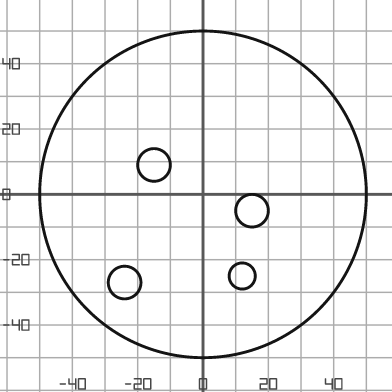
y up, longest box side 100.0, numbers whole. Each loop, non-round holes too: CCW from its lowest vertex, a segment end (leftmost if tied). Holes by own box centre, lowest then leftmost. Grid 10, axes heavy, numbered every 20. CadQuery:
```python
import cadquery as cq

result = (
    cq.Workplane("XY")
    .moveTo(0.0, 0.0)
    .circle(50.0)
    .moveTo(-24.0, -27.0)
    .circle(5.0)
    .moveTo(12.0, -25.0)
    .circle(4.0)
    .moveTo(15.0, -5.0)
    .circle(5.0)
    .moveTo(-15.0, 9.0)
    .circle(5.0)
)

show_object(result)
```